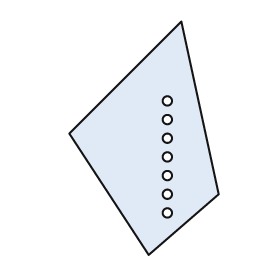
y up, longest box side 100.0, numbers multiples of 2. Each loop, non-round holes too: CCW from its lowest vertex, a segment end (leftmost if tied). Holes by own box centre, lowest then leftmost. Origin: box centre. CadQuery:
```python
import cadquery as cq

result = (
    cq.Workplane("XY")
    .moveTo(2.0, -50.0)
    .lineTo(32.0, -24.0)
    .lineTo(16.0, 50.0)
    .lineTo(-32.0, 2.0)
    .close()
    .moveTo(10.0, -32.0)
    .circle(2.0)
    .moveTo(10.0, -24.0)
    .circle(2.0)
    .moveTo(10.0, -16.0)
    .circle(2.0)
    .moveTo(10.0, -8.0)
    .circle(2.0)
    .moveTo(10.0, 0.0)
    .circle(2.0)
    .moveTo(10.0, 8.0)
    .circle(2.0)
    .moveTo(10.0, 16.0)
    .circle(2.0)
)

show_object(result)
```